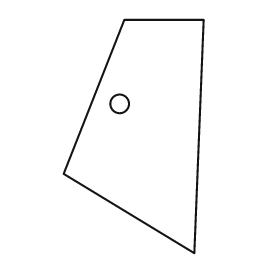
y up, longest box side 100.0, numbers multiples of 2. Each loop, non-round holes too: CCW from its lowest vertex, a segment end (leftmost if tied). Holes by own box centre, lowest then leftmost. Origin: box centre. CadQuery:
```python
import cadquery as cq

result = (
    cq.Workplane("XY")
    .moveTo(26.0, -50.0)
    .lineTo(30.0, 50.0)
    .lineTo(-4.0, 50.0)
    .lineTo(-30.0, -16.0)
    .close()
    .moveTo(-6.0, 14.0)
    .circle(4.0)
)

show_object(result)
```